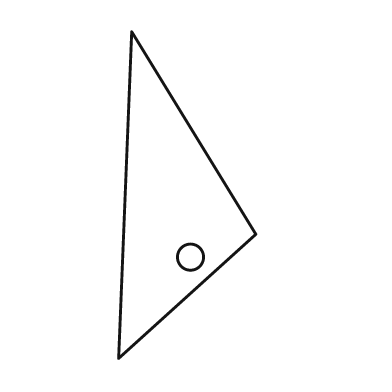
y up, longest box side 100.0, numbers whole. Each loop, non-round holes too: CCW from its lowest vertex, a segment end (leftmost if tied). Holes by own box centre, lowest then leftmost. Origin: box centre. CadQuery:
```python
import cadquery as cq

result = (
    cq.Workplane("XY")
    .moveTo(-21.0, -50.0)
    .lineTo(21.0, -12.0)
    .lineTo(-17.0, 50.0)
    .close()
    .moveTo(1.0, -19.0)
    .circle(4.0)
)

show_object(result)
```